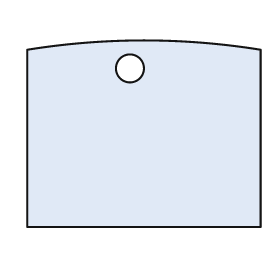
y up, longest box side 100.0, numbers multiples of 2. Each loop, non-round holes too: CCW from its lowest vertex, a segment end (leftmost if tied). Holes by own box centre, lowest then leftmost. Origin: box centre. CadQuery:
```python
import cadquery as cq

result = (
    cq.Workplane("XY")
    .moveTo(-50.0, -40.0)
    .lineTo(50.0, -40.0)
    .lineTo(50.0, 36.0)
    .threePointArc((0.0, 40.0), (-50.0, 36.0))
    .close()
    .moveTo(-6.0, 28.0)
    .circle(6.0)
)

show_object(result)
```